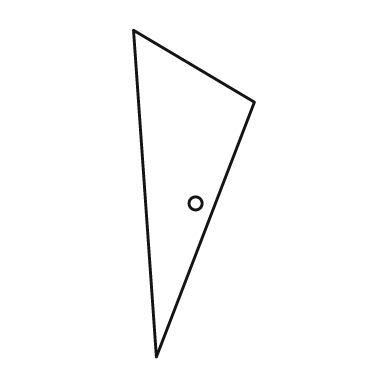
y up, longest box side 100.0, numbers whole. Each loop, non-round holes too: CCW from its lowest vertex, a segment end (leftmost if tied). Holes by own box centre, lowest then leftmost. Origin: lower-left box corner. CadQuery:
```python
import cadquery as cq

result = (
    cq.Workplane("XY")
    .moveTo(7.0, 0.0)
    .lineTo(37.0, 78.0)
    .lineTo(0.0, 100.0)
    .close()
    .moveTo(19.0, 47.0)
    .circle(2.0)
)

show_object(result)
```